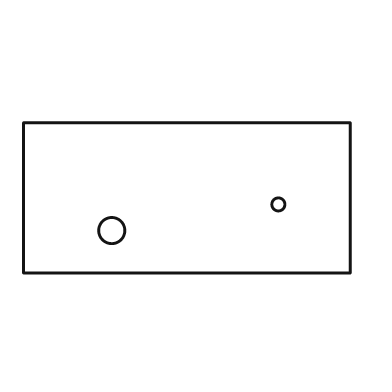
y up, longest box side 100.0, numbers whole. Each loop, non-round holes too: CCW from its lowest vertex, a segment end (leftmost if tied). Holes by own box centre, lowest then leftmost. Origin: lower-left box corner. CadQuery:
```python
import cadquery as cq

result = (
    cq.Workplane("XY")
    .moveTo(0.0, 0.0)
    .lineTo(100.0, 0.0)
    .lineTo(100.0, 46.0)
    .lineTo(0.0, 46.0)
    .close()
    .moveTo(27.0, 13.0)
    .circle(4.0)
    .moveTo(78.0, 21.0)
    .circle(2.0)
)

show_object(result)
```